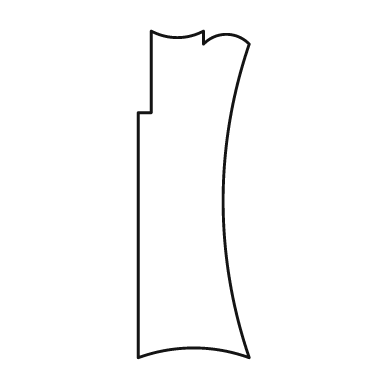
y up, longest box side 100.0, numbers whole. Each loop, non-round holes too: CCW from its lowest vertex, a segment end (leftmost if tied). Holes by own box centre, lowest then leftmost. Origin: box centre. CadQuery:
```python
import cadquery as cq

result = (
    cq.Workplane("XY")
    .moveTo(-17.0, -50.0)
    .threePointArc((0.0, -47.0), (17.0, -50.0))
    .threePointArc((9.0, -2.0), (17.0, 46.0))
    .threePointArc((10.0, 49.0), (3.0, 46.0))
    .lineTo(3.0, 50.0)
    .threePointArc((-5.0, 48.0), (-13.0, 50.0))
    .lineTo(-13.0, 25.0)
    .lineTo(-17.0, 25.0)
    .close()
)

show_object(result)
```